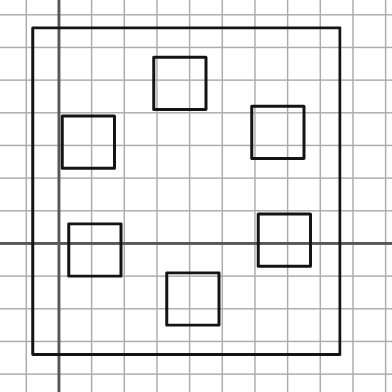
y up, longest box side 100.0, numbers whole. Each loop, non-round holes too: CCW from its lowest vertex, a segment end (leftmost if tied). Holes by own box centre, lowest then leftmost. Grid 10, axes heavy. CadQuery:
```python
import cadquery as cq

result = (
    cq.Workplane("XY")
    .moveTo(-8.0, -34.0)
    .lineTo(86.0, -34.0)
    .lineTo(86.0, 66.0)
    .lineTo(-8.0, 66.0)
    .close()
    .moveTo(33.0, -25.0)
    .lineTo(49.0, -25.0)
    .lineTo(49.0, -9.0)
    .lineTo(33.0, -9.0)
    .close()
    .moveTo(3.0, -10.0)
    .lineTo(19.0, -10.0)
    .lineTo(19.0, 6.0)
    .lineTo(3.0, 6.0)
    .close()
    .moveTo(61.0, -7.0)
    .lineTo(77.0, -7.0)
    .lineTo(77.0, 9.0)
    .lineTo(61.0, 9.0)
    .close()
    .moveTo(1.0, 23.0)
    .lineTo(17.0, 23.0)
    .lineTo(17.0, 39.0)
    .lineTo(1.0, 39.0)
    .close()
    .moveTo(59.0, 26.0)
    .lineTo(75.0, 26.0)
    .lineTo(75.0, 42.0)
    .lineTo(59.0, 42.0)
    .close()
    .moveTo(29.0, 41.0)
    .lineTo(45.0, 41.0)
    .lineTo(45.0, 57.0)
    .lineTo(29.0, 57.0)
    .close()
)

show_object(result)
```